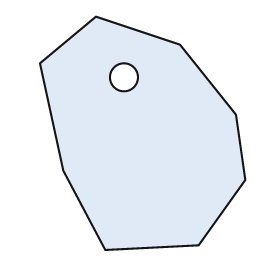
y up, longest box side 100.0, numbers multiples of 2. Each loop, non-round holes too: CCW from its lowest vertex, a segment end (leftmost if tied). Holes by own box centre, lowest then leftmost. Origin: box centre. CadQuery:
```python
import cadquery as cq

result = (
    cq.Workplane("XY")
    .moveTo(-16.0, -50.0)
    .lineTo(24.0, -48.0)
    .lineTo(44.0, -20.0)
    .lineTo(40.0, 8.0)
    .lineTo(16.0, 38.0)
    .lineTo(-20.0, 50.0)
    .lineTo(-44.0, 30.0)
    .lineTo(-34.0, -16.0)
    .close()
    .moveTo(-8.0, 24.0)
    .circle(6.0)
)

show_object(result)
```